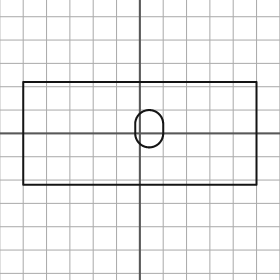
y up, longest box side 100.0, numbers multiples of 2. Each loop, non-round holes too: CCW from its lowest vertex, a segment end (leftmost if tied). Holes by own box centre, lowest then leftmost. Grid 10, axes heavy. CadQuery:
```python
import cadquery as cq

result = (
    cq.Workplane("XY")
    .moveTo(-50.0, -22.0)
    .lineTo(50.0, -22.0)
    .lineTo(50.0, 22.0)
    .lineTo(-50.0, 22.0)
    .close()
    .moveTo(-2.0, 0.0)
    .threePointArc((4.0, -6.0), (10.0, 0.0))
    .lineTo(10.0, 4.0)
    .threePointArc((4.0, 10.0), (-2.0, 4.0))
    .close()
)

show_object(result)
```